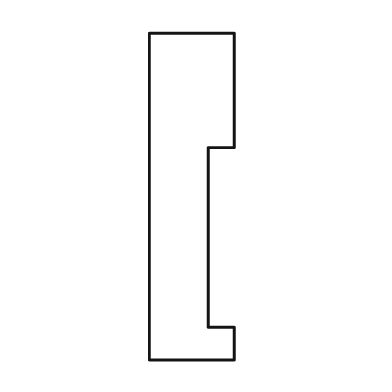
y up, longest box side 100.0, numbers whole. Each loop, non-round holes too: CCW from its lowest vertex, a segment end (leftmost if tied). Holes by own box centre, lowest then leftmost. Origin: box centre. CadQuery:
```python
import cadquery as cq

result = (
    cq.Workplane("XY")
    .moveTo(-13.0, -50.0)
    .lineTo(13.0, -50.0)
    .lineTo(13.0, -40.0)
    .lineTo(5.0, -40.0)
    .lineTo(5.0, 15.0)
    .lineTo(13.0, 15.0)
    .lineTo(13.0, 50.0)
    .lineTo(-13.0, 50.0)
    .close()
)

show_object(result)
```